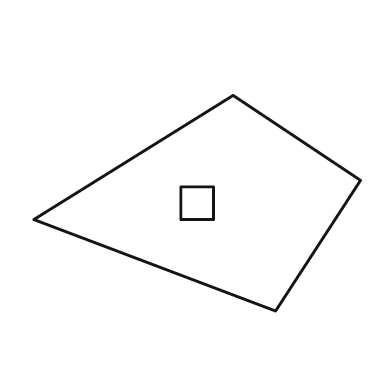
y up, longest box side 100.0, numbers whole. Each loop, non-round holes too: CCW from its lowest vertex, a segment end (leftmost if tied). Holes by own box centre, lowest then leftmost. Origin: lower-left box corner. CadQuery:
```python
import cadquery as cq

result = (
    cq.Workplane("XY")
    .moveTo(74.0, 0.0)
    .lineTo(100.0, 40.0)
    .lineTo(61.0, 66.0)
    .lineTo(0.0, 28.0)
    .close()
    .moveTo(45.0, 28.0)
    .lineTo(55.0, 28.0)
    .lineTo(55.0, 38.0)
    .lineTo(45.0, 38.0)
    .close()
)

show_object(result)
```